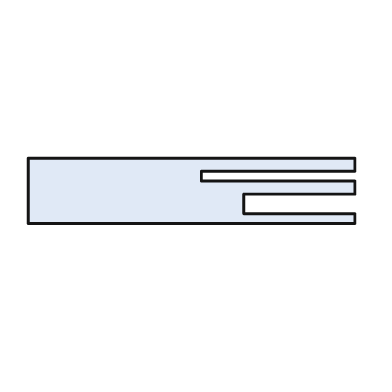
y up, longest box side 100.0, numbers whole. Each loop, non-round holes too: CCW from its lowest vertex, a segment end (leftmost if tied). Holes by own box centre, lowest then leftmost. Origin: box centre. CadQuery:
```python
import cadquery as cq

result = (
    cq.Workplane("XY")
    .moveTo(-50.0, -10.0)
    .lineTo(50.0, -10.0)
    .lineTo(50.0, -7.0)
    .lineTo(16.0, -7.0)
    .lineTo(16.0, -1.0)
    .lineTo(50.0, -1.0)
    .lineTo(50.0, 3.0)
    .lineTo(3.0, 3.0)
    .lineTo(3.0, 6.0)
    .lineTo(50.0, 6.0)
    .lineTo(50.0, 10.0)
    .lineTo(-50.0, 10.0)
    .close()
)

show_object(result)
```